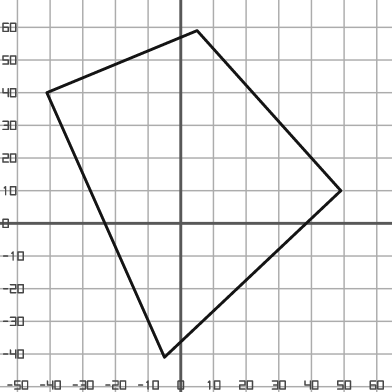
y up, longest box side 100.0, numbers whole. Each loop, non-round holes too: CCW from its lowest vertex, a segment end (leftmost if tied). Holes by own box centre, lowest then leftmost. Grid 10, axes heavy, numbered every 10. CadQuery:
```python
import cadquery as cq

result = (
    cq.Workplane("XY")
    .moveTo(-5.0, -41.0)
    .lineTo(49.0, 10.0)
    .lineTo(5.0, 59.0)
    .lineTo(-41.0, 40.0)
    .close()
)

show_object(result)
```